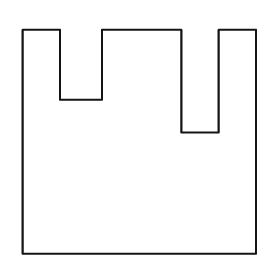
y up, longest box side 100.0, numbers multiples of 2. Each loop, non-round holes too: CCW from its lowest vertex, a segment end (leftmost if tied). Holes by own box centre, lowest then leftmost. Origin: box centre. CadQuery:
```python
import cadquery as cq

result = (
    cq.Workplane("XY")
    .moveTo(-50.0, -48.0)
    .lineTo(50.0, -48.0)
    .lineTo(50.0, 48.0)
    .lineTo(34.0, 48.0)
    .lineTo(34.0, 4.0)
    .lineTo(18.0, 4.0)
    .lineTo(18.0, 48.0)
    .lineTo(-16.0, 48.0)
    .lineTo(-16.0, 18.0)
    .lineTo(-34.0, 18.0)
    .lineTo(-34.0, 48.0)
    .lineTo(-50.0, 48.0)
    .close()
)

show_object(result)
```